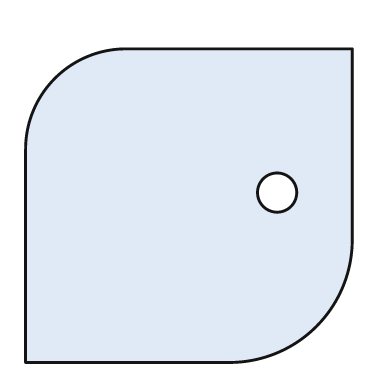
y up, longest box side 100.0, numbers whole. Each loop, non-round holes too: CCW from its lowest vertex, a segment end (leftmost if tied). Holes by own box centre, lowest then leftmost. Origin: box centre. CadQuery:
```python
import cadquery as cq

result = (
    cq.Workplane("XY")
    .moveTo(-50.0, -48.0)
    .lineTo(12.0, -48.0)
    .threePointArc((39.0, -37.0), (50.0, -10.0))
    .lineTo(50.0, 48.0)
    .lineTo(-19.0, 48.0)
    .threePointArc((-41.0, 39.0), (-50.0, 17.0))
    .close()
    .moveTo(27.0, 4.0)
    .circle(6.0)
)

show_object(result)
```